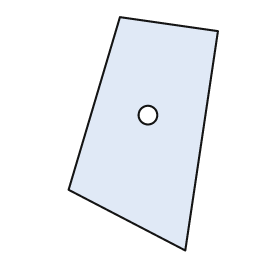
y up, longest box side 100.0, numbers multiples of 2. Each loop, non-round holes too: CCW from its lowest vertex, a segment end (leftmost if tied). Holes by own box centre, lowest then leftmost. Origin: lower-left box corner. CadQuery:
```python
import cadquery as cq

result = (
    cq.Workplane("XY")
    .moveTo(50.0, 0.0)
    .lineTo(64.0, 94.0)
    .lineTo(22.0, 100.0)
    .lineTo(0.0, 26.0)
    .close()
    .moveTo(34.0, 58.0)
    .circle(4.0)
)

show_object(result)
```